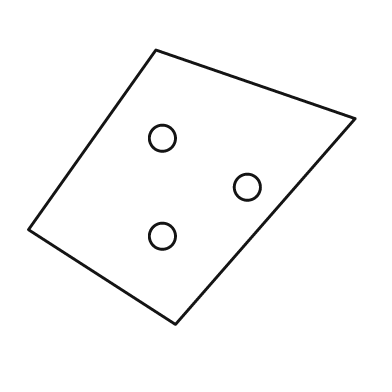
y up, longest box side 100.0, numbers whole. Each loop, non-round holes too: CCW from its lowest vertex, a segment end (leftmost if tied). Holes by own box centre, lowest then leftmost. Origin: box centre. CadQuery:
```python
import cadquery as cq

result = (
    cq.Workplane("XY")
    .moveTo(-5.0, -42.0)
    .lineTo(50.0, 21.0)
    .lineTo(-11.0, 42.0)
    .lineTo(-50.0, -13.0)
    .close()
    .moveTo(-9.0, -15.0)
    .circle(4.0)
    .moveTo(17.0, 0.0)
    .circle(4.0)
    .moveTo(-9.0, 15.0)
    .circle(4.0)
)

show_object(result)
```